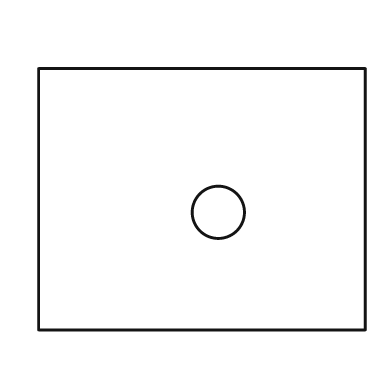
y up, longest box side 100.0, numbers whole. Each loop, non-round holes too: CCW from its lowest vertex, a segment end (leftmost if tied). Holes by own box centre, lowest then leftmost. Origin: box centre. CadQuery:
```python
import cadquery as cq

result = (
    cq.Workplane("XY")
    .moveTo(-50.0, -40.0)
    .lineTo(50.0, -40.0)
    .lineTo(50.0, 40.0)
    .lineTo(-50.0, 40.0)
    .close()
    .moveTo(5.0, -4.0)
    .circle(8.0)
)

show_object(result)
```